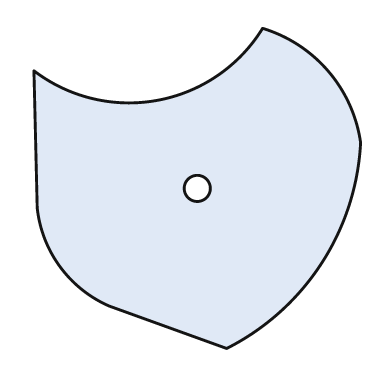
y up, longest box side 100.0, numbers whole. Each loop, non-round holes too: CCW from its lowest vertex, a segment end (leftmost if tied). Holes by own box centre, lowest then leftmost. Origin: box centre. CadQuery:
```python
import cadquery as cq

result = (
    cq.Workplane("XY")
    .moveTo(9.0, -49.0)
    .threePointArc((38.0, -23.0), (50.0, 14.0))
    .threePointArc((40.0, 36.0), (20.0, 49.0))
    .threePointArc((-12.0, 27.0), (-50.0, 36.0))
    .lineTo(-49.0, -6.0)
    .threePointArc((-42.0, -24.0), (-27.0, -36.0))
    .close()
    .moveTo(0.0, 0.0)
    .circle(4.0)
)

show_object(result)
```